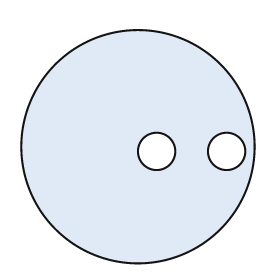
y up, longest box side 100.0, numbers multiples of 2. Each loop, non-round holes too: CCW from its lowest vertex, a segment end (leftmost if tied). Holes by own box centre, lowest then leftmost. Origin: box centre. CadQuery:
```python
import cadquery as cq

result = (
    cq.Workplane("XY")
    .moveTo(0.0, 0.0)
    .circle(50.0)
    .moveTo(8.0, -2.0)
    .circle(8.0)
    .moveTo(38.0, -2.0)
    .circle(8.0)
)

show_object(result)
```